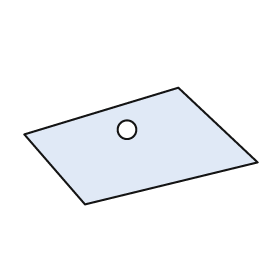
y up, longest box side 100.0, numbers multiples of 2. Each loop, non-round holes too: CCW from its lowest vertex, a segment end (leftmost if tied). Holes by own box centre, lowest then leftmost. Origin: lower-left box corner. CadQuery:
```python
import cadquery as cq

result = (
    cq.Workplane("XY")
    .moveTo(26.0, 0.0)
    .lineTo(100.0, 18.0)
    .lineTo(66.0, 50.0)
    .lineTo(0.0, 30.0)
    .close()
    .moveTo(44.0, 32.0)
    .circle(4.0)
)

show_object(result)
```